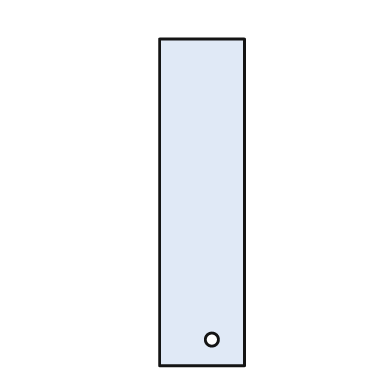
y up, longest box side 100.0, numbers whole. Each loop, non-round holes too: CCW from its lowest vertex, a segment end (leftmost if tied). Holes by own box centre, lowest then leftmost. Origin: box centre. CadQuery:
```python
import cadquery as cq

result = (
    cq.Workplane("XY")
    .moveTo(-13.0, -50.0)
    .lineTo(13.0, -50.0)
    .lineTo(13.0, 50.0)
    .lineTo(-13.0, 50.0)
    .close()
    .moveTo(3.0, -42.0)
    .circle(2.0)
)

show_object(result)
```